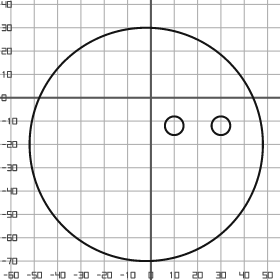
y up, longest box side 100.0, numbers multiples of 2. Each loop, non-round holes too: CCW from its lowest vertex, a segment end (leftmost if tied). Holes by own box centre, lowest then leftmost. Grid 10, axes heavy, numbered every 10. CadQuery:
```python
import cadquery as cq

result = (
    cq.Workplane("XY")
    .moveTo(-2.0, -20.0)
    .circle(50.0)
    .moveTo(10.0, -12.0)
    .circle(4.0)
    .moveTo(30.0, -12.0)
    .circle(4.0)
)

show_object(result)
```